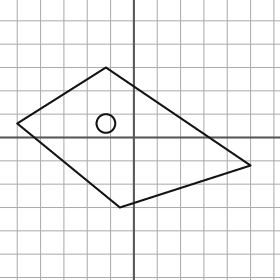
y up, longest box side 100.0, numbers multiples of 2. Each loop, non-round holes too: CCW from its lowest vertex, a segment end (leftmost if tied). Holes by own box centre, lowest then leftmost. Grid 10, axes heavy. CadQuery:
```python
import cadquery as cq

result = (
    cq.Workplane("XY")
    .moveTo(-6.0, -30.0)
    .lineTo(50.0, -12.0)
    .lineTo(-12.0, 30.0)
    .lineTo(-50.0, 6.0)
    .close()
    .moveTo(-12.0, 6.0)
    .circle(4.0)
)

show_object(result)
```